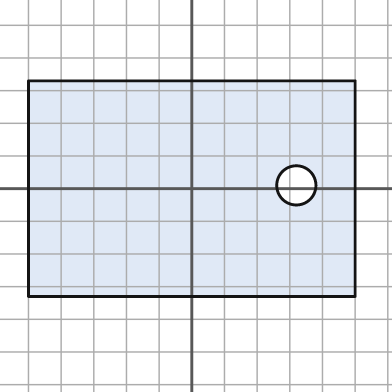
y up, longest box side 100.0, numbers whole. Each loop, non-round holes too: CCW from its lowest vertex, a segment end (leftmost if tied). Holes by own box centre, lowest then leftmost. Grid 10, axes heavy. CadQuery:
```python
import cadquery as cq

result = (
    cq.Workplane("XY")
    .moveTo(-50.0, -33.0)
    .lineTo(50.0, -33.0)
    .lineTo(50.0, 33.0)
    .lineTo(-50.0, 33.0)
    .close()
    .moveTo(32.0, 1.0)
    .circle(6.0)
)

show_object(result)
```